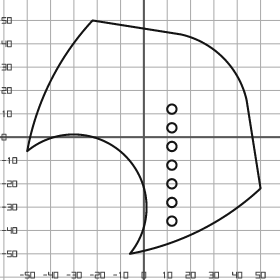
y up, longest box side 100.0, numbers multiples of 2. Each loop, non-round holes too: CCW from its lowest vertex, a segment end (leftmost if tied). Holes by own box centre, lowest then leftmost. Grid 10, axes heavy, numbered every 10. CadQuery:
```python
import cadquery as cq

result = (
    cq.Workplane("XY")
    .moveTo(-6.0, -50.0)
    .threePointArc((24.0, -40.0), (50.0, -22.0))
    .lineTo(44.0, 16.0)
    .threePointArc((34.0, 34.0), (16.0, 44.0))
    .lineTo(-22.0, 50.0)
    .threePointArc((-40.0, 24.0), (-50.0, -6.0))
    .threePointArc((-8.0, -8.0), (-6.0, -50.0))
    .close()
    .moveTo(12.0, -36.0)
    .circle(2.0)
    .moveTo(12.0, -28.0)
    .circle(2.0)
    .moveTo(12.0, -20.0)
    .circle(2.0)
    .moveTo(12.0, -12.0)
    .circle(2.0)
    .moveTo(12.0, -4.0)
    .circle(2.0)
    .moveTo(12.0, 4.0)
    .circle(2.0)
    .moveTo(12.0, 12.0)
    .circle(2.0)
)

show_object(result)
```